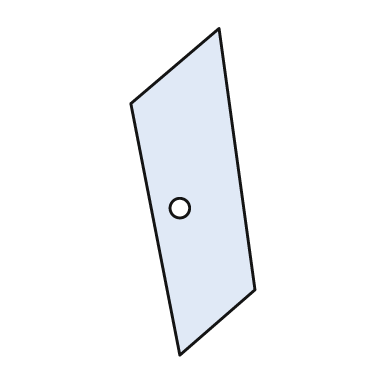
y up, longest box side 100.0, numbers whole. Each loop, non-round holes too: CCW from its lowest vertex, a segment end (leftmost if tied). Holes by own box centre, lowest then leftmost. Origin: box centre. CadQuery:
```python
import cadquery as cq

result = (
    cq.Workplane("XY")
    .moveTo(-4.0, -50.0)
    .lineTo(19.0, -30.0)
    .lineTo(8.0, 50.0)
    .lineTo(-19.0, 27.0)
    .close()
    .moveTo(-4.0, -5.0)
    .circle(3.0)
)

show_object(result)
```